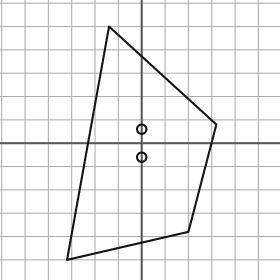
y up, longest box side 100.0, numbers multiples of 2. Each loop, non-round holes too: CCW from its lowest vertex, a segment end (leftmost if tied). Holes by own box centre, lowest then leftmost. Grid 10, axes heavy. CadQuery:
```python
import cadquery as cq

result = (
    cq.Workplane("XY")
    .moveTo(-32.0, -50.0)
    .lineTo(20.0, -38.0)
    .lineTo(32.0, 8.0)
    .lineTo(-14.0, 50.0)
    .close()
    .moveTo(0.0, -6.0)
    .circle(2.0)
    .moveTo(0.0, 6.0)
    .circle(2.0)
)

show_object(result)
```